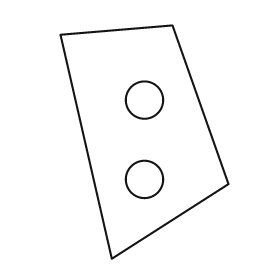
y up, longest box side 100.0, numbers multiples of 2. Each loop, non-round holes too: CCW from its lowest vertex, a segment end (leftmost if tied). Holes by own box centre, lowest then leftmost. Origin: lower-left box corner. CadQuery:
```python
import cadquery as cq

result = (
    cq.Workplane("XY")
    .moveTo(22.0, 0.0)
    .lineTo(72.0, 32.0)
    .lineTo(48.0, 100.0)
    .lineTo(0.0, 96.0)
    .close()
    .moveTo(36.0, 34.0)
    .circle(8.0)
    .moveTo(36.0, 68.0)
    .circle(8.0)
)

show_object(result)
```